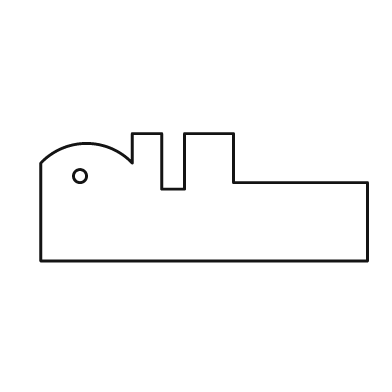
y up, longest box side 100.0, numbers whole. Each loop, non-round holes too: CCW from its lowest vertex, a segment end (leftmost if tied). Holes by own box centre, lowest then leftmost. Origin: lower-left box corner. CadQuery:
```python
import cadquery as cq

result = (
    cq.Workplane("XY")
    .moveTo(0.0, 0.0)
    .lineTo(100.0, 0.0)
    .lineTo(100.0, 24.0)
    .lineTo(59.0, 24.0)
    .lineTo(59.0, 39.0)
    .lineTo(44.0, 39.0)
    .lineTo(44.0, 22.0)
    .lineTo(37.0, 22.0)
    .lineTo(37.0, 39.0)
    .lineTo(28.0, 39.0)
    .lineTo(28.0, 30.0)
    .threePointArc((14.0, 36.0), (0.0, 30.0))
    .close()
    .moveTo(12.0, 26.0)
    .circle(2.0)
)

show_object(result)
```